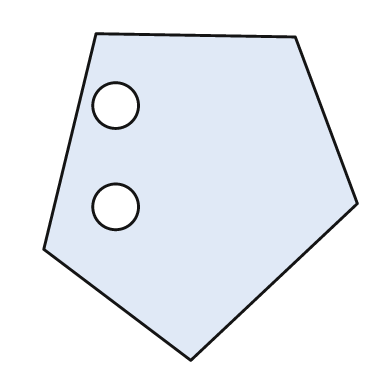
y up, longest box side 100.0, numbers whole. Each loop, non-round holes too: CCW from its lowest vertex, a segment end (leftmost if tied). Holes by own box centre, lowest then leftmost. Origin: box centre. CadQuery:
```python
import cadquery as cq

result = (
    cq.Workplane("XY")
    .moveTo(-3.0, -50.0)
    .lineTo(48.0, -2.0)
    .lineTo(29.0, 49.0)
    .lineTo(-32.0, 50.0)
    .lineTo(-48.0, -16.0)
    .close()
    .moveTo(-26.0, -3.0)
    .circle(7.0)
    .moveTo(-26.0, 28.0)
    .circle(7.0)
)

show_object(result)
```